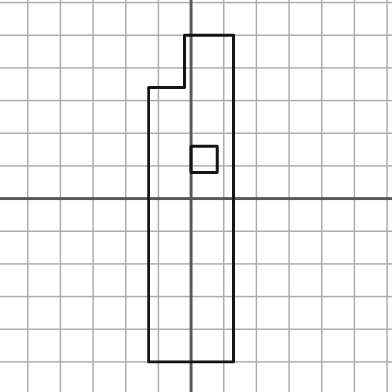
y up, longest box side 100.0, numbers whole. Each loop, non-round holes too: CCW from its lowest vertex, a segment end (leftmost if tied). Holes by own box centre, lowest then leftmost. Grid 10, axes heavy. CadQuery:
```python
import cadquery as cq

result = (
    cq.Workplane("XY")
    .moveTo(-13.0, -50.0)
    .lineTo(13.0, -50.0)
    .lineTo(13.0, 50.0)
    .lineTo(-2.0, 50.0)
    .lineTo(-2.0, 34.0)
    .lineTo(-13.0, 34.0)
    .close()
    .moveTo(0.0, 8.0)
    .lineTo(8.0, 8.0)
    .lineTo(8.0, 16.0)
    .lineTo(0.0, 16.0)
    .close()
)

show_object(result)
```